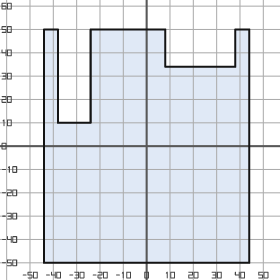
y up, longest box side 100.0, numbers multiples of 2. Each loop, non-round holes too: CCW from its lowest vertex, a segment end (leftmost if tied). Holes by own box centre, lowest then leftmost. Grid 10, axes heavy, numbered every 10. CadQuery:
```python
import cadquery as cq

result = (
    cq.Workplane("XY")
    .moveTo(-44.0, -50.0)
    .lineTo(44.0, -50.0)
    .lineTo(44.0, 50.0)
    .lineTo(38.0, 50.0)
    .lineTo(38.0, 34.0)
    .lineTo(8.0, 34.0)
    .lineTo(8.0, 50.0)
    .lineTo(-24.0, 50.0)
    .lineTo(-24.0, 10.0)
    .lineTo(-38.0, 10.0)
    .lineTo(-38.0, 50.0)
    .lineTo(-44.0, 50.0)
    .close()
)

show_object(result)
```